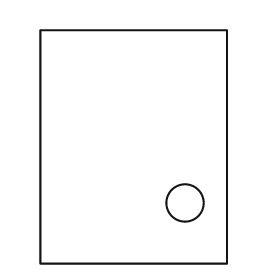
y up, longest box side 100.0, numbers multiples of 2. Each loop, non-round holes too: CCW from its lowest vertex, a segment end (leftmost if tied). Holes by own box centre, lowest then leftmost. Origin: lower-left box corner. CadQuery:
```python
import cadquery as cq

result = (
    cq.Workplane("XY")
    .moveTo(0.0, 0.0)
    .lineTo(80.0, 0.0)
    .lineTo(80.0, 100.0)
    .lineTo(0.0, 100.0)
    .close()
    .moveTo(62.0, 26.0)
    .circle(8.0)
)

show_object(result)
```